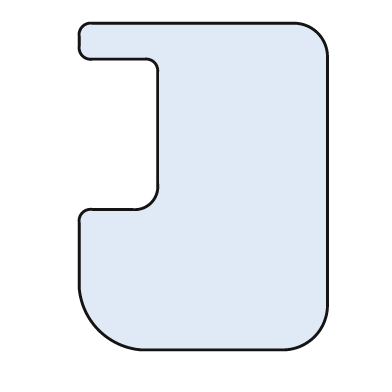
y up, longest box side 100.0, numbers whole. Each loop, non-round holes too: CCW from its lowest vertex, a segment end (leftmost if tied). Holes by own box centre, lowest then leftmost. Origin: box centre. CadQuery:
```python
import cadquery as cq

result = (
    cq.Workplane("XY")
    .moveTo(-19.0, -50.0)
    .lineTo(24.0, -50.0)
    .threePointArc((34.0, -46.0), (38.0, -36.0))
    .lineTo(38.0, 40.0)
    .threePointArc((35.0, 47.0), (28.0, 50.0))
    .lineTo(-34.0, 50.0)
    .threePointArc((-37.0, 49.0), (-38.0, 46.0))
    .lineTo(-38.0, 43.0)
    .threePointArc((-37.0, 40.0), (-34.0, 39.0))
    .lineTo(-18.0, 39.0)
    .threePointArc((-15.0, 38.0), (-14.0, 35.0))
    .lineTo(-14.0, 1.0)
    .threePointArc((-16.0, -5.0), (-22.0, -7.0))
    .lineTo(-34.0, -7.0)
    .threePointArc((-37.0, -8.0), (-38.0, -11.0))
    .lineTo(-38.0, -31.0)
    .threePointArc((-32.0, -44.0), (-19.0, -50.0))
    .close()
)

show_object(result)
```